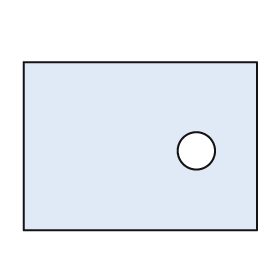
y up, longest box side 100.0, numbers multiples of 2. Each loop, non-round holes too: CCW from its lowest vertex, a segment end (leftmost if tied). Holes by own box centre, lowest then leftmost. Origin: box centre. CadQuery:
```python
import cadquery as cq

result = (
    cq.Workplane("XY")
    .moveTo(-50.0, -36.0)
    .lineTo(50.0, -36.0)
    .lineTo(50.0, 36.0)
    .lineTo(-50.0, 36.0)
    .close()
    .moveTo(24.0, -2.0)
    .circle(8.0)
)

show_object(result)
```